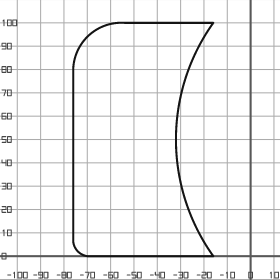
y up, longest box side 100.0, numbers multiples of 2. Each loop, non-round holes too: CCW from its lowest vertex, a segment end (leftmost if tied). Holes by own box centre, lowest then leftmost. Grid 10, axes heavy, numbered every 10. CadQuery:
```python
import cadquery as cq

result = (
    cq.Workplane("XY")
    .moveTo(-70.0, 0.0)
    .lineTo(-16.0, 0.0)
    .threePointArc((-32.0, 50.0), (-16.0, 100.0))
    .lineTo(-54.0, 100.0)
    .threePointArc((-70.0, 94.0), (-76.0, 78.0))
    .lineTo(-76.0, 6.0)
    .threePointArc((-74.0, 2.0), (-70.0, 0.0))
    .close()
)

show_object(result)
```